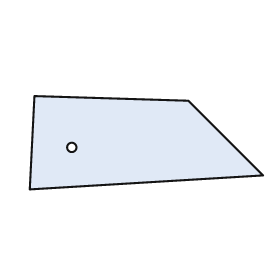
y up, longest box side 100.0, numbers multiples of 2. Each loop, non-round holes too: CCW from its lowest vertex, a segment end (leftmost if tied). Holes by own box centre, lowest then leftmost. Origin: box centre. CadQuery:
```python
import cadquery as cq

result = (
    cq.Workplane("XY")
    .moveTo(-50.0, -20.0)
    .lineTo(50.0, -14.0)
    .lineTo(18.0, 18.0)
    .lineTo(-48.0, 20.0)
    .close()
    .moveTo(-32.0, -2.0)
    .circle(2.0)
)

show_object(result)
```